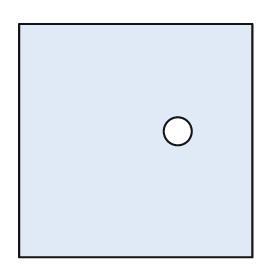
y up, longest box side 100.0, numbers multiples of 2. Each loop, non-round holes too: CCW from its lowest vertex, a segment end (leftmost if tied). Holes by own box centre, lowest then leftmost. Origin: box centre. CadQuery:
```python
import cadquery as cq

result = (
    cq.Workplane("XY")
    .moveTo(-50.0, -50.0)
    .lineTo(50.0, -50.0)
    .lineTo(50.0, 50.0)
    .lineTo(-50.0, 50.0)
    .close()
    .moveTo(18.0, 4.0)
    .circle(6.0)
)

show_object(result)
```